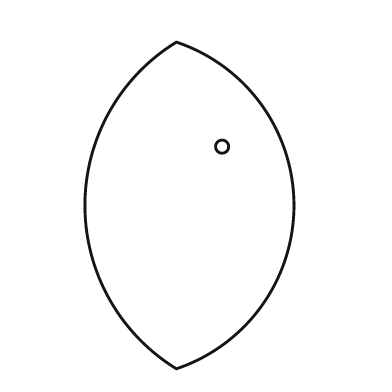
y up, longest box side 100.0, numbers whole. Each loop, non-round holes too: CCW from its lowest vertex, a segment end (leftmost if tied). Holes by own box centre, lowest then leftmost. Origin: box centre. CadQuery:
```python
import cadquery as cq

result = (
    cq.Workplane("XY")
    .moveTo(-4.0, -50.0)
    .threePointArc((32.0, 0.0), (-4.0, 50.0))
    .threePointArc((-32.0, 0.0), (-4.0, -50.0))
    .close()
    .moveTo(10.0, 18.0)
    .circle(2.0)
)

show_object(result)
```